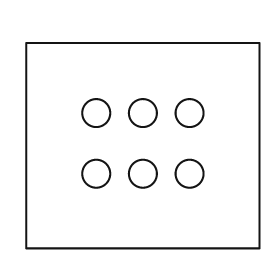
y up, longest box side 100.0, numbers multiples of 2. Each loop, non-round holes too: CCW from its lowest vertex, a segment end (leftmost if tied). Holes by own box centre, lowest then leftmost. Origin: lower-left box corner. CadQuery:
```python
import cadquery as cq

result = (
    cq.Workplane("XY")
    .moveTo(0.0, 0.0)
    .lineTo(100.0, 0.0)
    .lineTo(100.0, 88.0)
    .lineTo(0.0, 88.0)
    .close()
    .moveTo(30.0, 32.0)
    .circle(6.0)
    .moveTo(50.0, 32.0)
    .circle(6.0)
    .moveTo(70.0, 32.0)
    .circle(6.0)
    .moveTo(30.0, 58.0)
    .circle(6.0)
    .moveTo(50.0, 58.0)
    .circle(6.0)
    .moveTo(70.0, 58.0)
    .circle(6.0)
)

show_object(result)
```